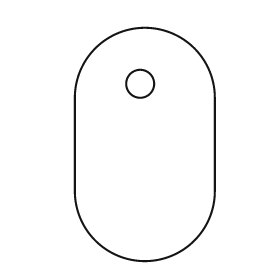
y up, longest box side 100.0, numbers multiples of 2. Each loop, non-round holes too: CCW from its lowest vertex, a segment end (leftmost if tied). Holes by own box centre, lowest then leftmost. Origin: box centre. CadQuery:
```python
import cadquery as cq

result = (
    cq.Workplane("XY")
    .moveTo(-30.0, -20.0)
    .threePointArc((0.0, -50.0), (30.0, -20.0))
    .lineTo(30.0, 20.0)
    .threePointArc((0.0, 50.0), (-30.0, 20.0))
    .close()
    .moveTo(-2.0, 26.0)
    .circle(6.0)
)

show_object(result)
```